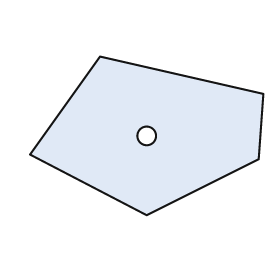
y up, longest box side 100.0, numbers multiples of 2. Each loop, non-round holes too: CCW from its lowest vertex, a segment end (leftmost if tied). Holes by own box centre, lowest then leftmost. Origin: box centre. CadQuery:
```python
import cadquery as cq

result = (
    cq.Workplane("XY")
    .moveTo(0.0, -34.0)
    .lineTo(48.0, -10.0)
    .lineTo(50.0, 18.0)
    .lineTo(-20.0, 34.0)
    .lineTo(-50.0, -8.0)
    .close()
    .moveTo(0.0, 0.0)
    .circle(4.0)
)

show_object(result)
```